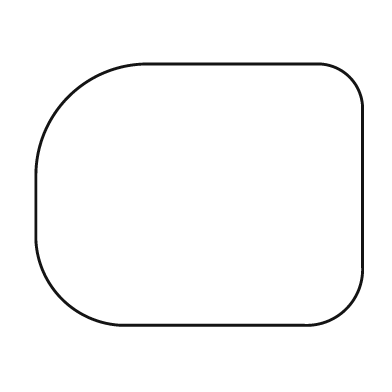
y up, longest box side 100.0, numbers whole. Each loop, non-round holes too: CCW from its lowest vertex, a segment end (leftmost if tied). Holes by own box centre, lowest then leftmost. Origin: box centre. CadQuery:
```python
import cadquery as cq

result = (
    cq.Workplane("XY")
    .moveTo(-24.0, -40.0)
    .lineTo(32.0, -40.0)
    .threePointArc((45.0, -35.0), (50.0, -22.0))
    .lineTo(50.0, 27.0)
    .threePointArc((46.0, 36.0), (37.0, 40.0))
    .lineTo(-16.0, 40.0)
    .threePointArc((-40.0, 30.0), (-50.0, 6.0))
    .lineTo(-50.0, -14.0)
    .threePointArc((-42.0, -32.0), (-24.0, -40.0))
    .close()
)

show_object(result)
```